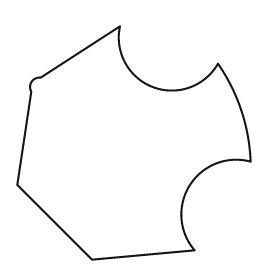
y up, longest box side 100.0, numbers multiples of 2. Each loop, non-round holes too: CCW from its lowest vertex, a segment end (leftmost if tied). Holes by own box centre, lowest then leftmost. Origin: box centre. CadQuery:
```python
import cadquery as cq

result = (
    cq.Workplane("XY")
    .moveTo(-18.0, -50.0)
    .lineTo(26.0, -46.0)
    .threePointArc((24.0, -18.0), (50.0, -8.0))
    .threePointArc((46.0, 14.0), (36.0, 34.0))
    .threePointArc((8.0, 24.0), (-6.0, 50.0))
    .lineTo(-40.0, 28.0)
    .threePointArc((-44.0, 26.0), (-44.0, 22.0))
    .lineTo(-50.0, -18.0)
    .close()
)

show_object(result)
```